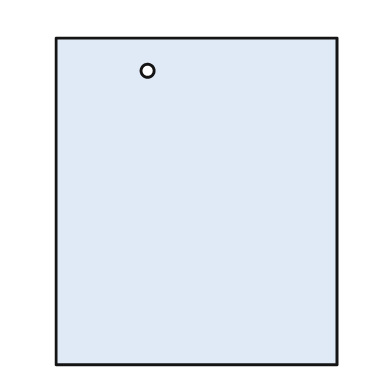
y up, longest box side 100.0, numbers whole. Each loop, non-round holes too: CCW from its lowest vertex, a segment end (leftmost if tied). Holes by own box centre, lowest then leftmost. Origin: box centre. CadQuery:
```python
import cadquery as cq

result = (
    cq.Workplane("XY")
    .moveTo(-43.0, -50.0)
    .lineTo(43.0, -50.0)
    .lineTo(43.0, 50.0)
    .lineTo(-43.0, 50.0)
    .close()
    .moveTo(-15.0, 40.0)
    .circle(2.0)
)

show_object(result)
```